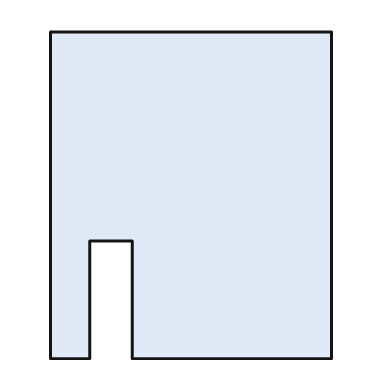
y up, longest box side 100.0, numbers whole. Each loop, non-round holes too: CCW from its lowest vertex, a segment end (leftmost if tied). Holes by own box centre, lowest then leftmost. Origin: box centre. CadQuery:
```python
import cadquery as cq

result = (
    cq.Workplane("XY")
    .moveTo(-43.0, -50.0)
    .lineTo(-31.0, -50.0)
    .lineTo(-31.0, -14.0)
    .lineTo(-18.0, -14.0)
    .lineTo(-18.0, -50.0)
    .lineTo(43.0, -50.0)
    .lineTo(43.0, 50.0)
    .lineTo(-43.0, 50.0)
    .close()
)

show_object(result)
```